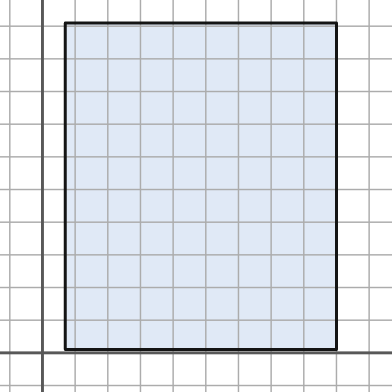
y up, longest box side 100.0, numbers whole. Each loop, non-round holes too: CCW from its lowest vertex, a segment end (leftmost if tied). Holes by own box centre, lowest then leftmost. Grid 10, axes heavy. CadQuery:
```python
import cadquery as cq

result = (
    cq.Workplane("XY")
    .moveTo(7.0, 1.0)
    .lineTo(90.0, 1.0)
    .lineTo(90.0, 101.0)
    .lineTo(7.0, 101.0)
    .close()
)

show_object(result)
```